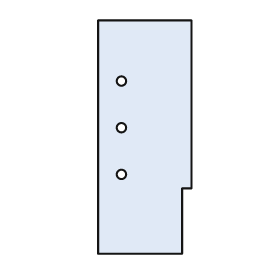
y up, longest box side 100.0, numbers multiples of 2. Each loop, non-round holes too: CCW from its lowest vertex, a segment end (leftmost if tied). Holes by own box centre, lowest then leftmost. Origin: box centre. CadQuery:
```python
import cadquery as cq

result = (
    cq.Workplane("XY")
    .moveTo(-20.0, -50.0)
    .lineTo(16.0, -50.0)
    .lineTo(16.0, -22.0)
    .lineTo(20.0, -22.0)
    .lineTo(20.0, 50.0)
    .lineTo(-20.0, 50.0)
    .close()
    .moveTo(-10.0, -16.0)
    .circle(2.0)
    .moveTo(-10.0, 4.0)
    .circle(2.0)
    .moveTo(-10.0, 24.0)
    .circle(2.0)
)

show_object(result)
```